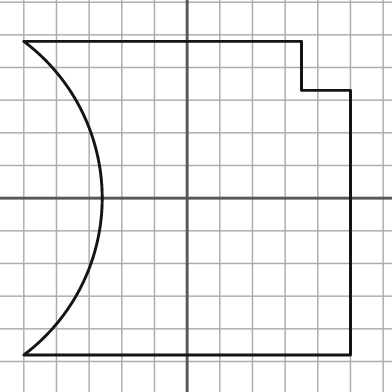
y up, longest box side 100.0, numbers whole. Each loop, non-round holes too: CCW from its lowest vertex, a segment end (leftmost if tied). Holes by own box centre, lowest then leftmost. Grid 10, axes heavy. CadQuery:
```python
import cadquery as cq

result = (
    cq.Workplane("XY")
    .moveTo(-50.0, -48.0)
    .lineTo(50.0, -48.0)
    .lineTo(50.0, 33.0)
    .lineTo(35.0, 33.0)
    .lineTo(35.0, 48.0)
    .lineTo(-50.0, 48.0)
    .threePointArc((-26.0, 0.0), (-50.0, -48.0))
    .close()
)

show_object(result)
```